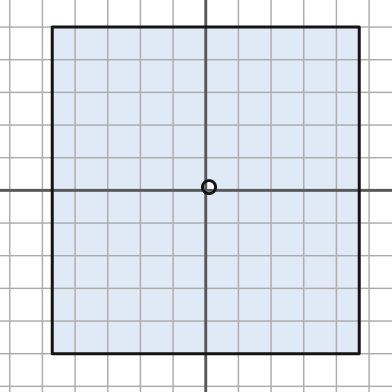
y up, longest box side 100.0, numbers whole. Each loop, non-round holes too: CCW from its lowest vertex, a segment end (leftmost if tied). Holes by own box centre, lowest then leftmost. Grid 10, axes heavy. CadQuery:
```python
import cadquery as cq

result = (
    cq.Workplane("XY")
    .moveTo(-47.0, -50.0)
    .lineTo(47.0, -50.0)
    .lineTo(47.0, 50.0)
    .lineTo(-47.0, 50.0)
    .close()
    .moveTo(1.0, 1.0)
    .circle(2.0)
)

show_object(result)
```